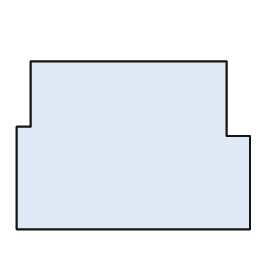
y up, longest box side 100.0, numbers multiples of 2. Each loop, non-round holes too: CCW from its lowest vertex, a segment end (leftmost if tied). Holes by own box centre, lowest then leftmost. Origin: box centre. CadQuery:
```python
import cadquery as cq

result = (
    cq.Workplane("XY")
    .moveTo(-50.0, -36.0)
    .lineTo(50.0, -36.0)
    .lineTo(50.0, 4.0)
    .lineTo(40.0, 4.0)
    .lineTo(40.0, 36.0)
    .lineTo(-44.0, 36.0)
    .lineTo(-44.0, 8.0)
    .lineTo(-50.0, 8.0)
    .close()
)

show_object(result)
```